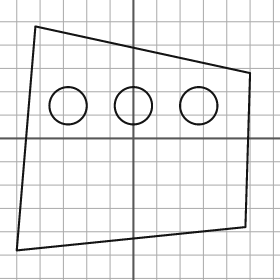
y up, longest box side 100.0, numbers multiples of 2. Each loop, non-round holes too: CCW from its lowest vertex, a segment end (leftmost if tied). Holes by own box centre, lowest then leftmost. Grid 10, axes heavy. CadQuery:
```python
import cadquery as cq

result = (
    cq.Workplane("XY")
    .moveTo(-50.0, -48.0)
    .lineTo(48.0, -38.0)
    .lineTo(50.0, 28.0)
    .lineTo(-42.0, 48.0)
    .close()
    .moveTo(-28.0, 14.0)
    .circle(8.0)
    .moveTo(0.0, 14.0)
    .circle(8.0)
    .moveTo(28.0, 14.0)
    .circle(8.0)
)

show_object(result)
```